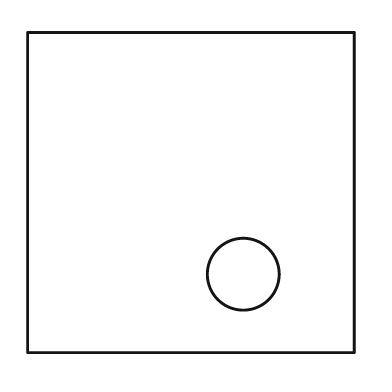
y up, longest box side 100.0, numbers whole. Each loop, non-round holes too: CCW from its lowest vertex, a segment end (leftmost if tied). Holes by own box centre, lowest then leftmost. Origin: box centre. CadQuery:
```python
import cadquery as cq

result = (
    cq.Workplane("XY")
    .moveTo(-50.0, -49.0)
    .lineTo(50.0, -49.0)
    .lineTo(50.0, 49.0)
    .lineTo(-50.0, 49.0)
    .close()
    .moveTo(16.0, -25.0)
    .circle(11.0)
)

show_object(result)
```